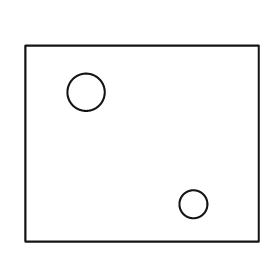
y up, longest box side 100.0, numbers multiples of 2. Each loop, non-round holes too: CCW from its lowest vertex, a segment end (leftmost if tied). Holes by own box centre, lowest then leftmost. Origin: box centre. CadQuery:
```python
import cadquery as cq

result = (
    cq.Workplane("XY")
    .moveTo(-50.0, -42.0)
    .lineTo(50.0, -42.0)
    .lineTo(50.0, 42.0)
    .lineTo(-50.0, 42.0)
    .close()
    .moveTo(22.0, -26.0)
    .circle(6.0)
    .moveTo(-24.0, 22.0)
    .circle(8.0)
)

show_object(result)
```